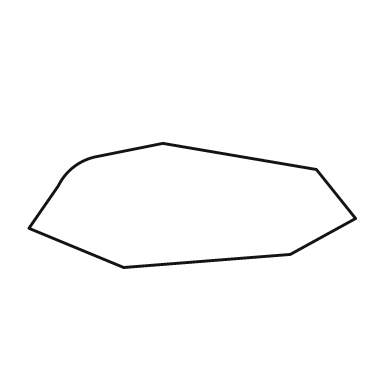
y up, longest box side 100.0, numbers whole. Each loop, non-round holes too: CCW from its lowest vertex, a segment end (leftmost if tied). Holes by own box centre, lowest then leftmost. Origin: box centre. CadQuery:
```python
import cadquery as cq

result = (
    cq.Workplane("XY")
    .moveTo(-21.0, -19.0)
    .lineTo(30.0, -15.0)
    .lineTo(50.0, -4.0)
    .lineTo(38.0, 11.0)
    .lineTo(-9.0, 19.0)
    .lineTo(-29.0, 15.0)
    .threePointArc((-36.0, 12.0), (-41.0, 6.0))
    .lineTo(-50.0, -7.0)
    .close()
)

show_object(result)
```